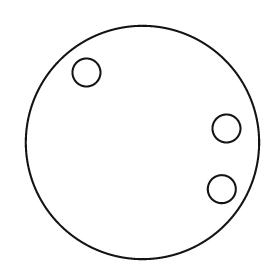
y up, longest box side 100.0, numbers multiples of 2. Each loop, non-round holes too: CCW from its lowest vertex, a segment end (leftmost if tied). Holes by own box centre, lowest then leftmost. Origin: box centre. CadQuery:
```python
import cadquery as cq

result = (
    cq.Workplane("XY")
    .moveTo(0.0, 0.0)
    .circle(50.0)
    .moveTo(34.0, -20.0)
    .circle(6.0)
    .moveTo(36.0, 6.0)
    .circle(6.0)
    .moveTo(-24.0, 30.0)
    .circle(6.0)
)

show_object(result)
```